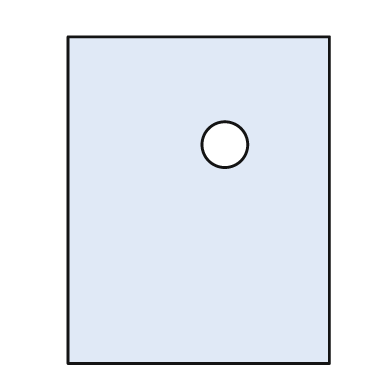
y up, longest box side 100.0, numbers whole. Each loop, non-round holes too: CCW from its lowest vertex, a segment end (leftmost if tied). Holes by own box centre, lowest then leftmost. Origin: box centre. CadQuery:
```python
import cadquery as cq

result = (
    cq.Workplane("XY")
    .moveTo(-40.0, -50.0)
    .lineTo(40.0, -50.0)
    .lineTo(40.0, 50.0)
    .lineTo(-40.0, 50.0)
    .close()
    .moveTo(8.0, 17.0)
    .circle(7.0)
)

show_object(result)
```